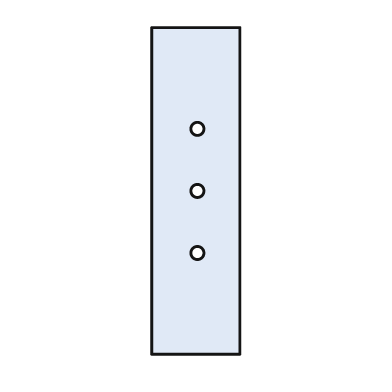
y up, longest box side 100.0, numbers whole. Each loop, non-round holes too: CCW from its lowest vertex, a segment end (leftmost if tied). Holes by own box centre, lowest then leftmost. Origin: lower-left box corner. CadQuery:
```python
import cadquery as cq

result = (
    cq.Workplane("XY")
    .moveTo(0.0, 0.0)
    .lineTo(27.0, 0.0)
    .lineTo(27.0, 100.0)
    .lineTo(0.0, 100.0)
    .close()
    .moveTo(14.0, 31.0)
    .circle(2.0)
    .moveTo(14.0, 50.0)
    .circle(2.0)
    .moveTo(14.0, 69.0)
    .circle(2.0)
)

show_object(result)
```